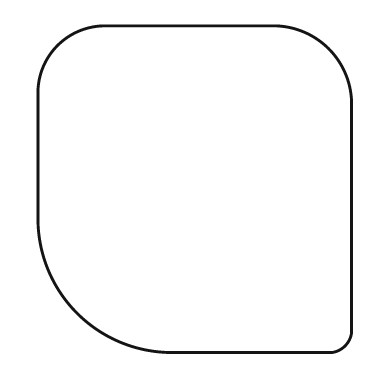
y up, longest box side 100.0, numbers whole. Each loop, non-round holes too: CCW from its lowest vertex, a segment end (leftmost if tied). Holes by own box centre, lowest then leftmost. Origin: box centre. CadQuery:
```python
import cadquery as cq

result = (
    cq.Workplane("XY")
    .moveTo(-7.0, -50.0)
    .lineTo(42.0, -50.0)
    .threePointArc((46.0, -48.0), (48.0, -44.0))
    .lineTo(48.0, 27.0)
    .threePointArc((41.0, 43.0), (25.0, 50.0))
    .lineTo(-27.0, 50.0)
    .threePointArc((-42.0, 44.0), (-48.0, 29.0))
    .lineTo(-48.0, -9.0)
    .threePointArc((-36.0, -38.0), (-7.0, -50.0))
    .close()
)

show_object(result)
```